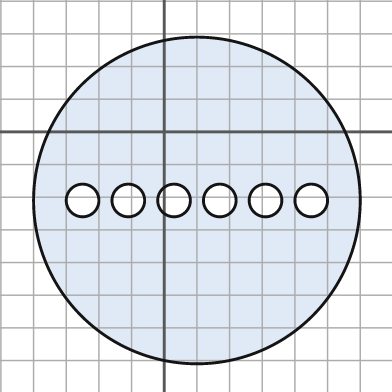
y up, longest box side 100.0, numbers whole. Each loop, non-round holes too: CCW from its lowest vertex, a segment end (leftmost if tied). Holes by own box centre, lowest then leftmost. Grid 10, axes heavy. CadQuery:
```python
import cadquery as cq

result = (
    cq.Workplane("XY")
    .moveTo(10.0, -21.0)
    .circle(50.0)
    .moveTo(-25.0, -21.0)
    .circle(5.0)
    .moveTo(-11.0, -21.0)
    .circle(5.0)
    .moveTo(3.0, -21.0)
    .circle(5.0)
    .moveTo(17.0, -21.0)
    .circle(5.0)
    .moveTo(31.0, -21.0)
    .circle(5.0)
    .moveTo(45.0, -21.0)
    .circle(5.0)
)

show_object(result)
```